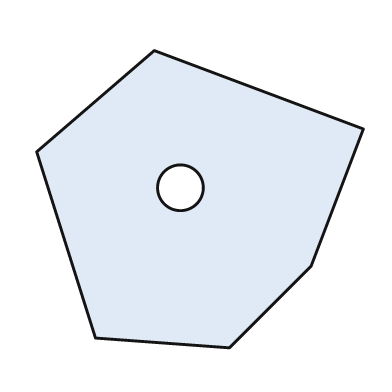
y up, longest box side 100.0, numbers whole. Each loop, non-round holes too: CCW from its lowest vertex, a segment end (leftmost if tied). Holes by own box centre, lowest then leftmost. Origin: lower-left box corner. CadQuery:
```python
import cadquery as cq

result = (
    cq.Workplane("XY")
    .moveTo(59.0, 0.0)
    .lineTo(84.0, 25.0)
    .lineTo(100.0, 67.0)
    .lineTo(36.0, 91.0)
    .lineTo(0.0, 60.0)
    .lineTo(18.0, 3.0)
    .close()
    .moveTo(44.0, 49.0)
    .circle(7.0)
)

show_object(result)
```